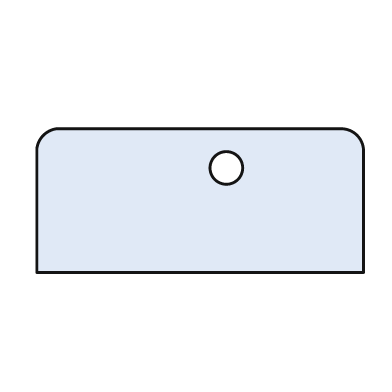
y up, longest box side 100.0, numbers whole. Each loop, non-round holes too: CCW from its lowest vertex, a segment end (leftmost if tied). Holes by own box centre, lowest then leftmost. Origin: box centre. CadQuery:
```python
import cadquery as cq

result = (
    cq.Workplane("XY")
    .moveTo(-50.0, -22.0)
    .lineTo(50.0, -22.0)
    .lineTo(50.0, 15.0)
    .threePointArc((48.0, 20.0), (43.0, 22.0))
    .lineTo(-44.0, 22.0)
    .threePointArc((-48.0, 20.0), (-50.0, 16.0))
    .close()
    .moveTo(8.0, 10.0)
    .circle(5.0)
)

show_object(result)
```